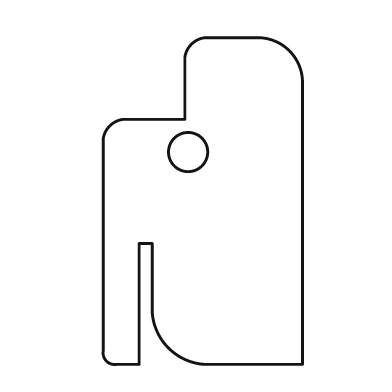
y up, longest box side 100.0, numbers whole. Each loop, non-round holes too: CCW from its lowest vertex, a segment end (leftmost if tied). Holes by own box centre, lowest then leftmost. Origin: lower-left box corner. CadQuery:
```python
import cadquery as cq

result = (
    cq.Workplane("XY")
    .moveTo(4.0, 0.0)
    .lineTo(11.0, 0.0)
    .lineTo(11.0, 37.0)
    .lineTo(15.0, 37.0)
    .lineTo(15.0, 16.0)
    .threePointArc((20.0, 5.0), (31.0, 0.0))
    .lineTo(61.0, 0.0)
    .lineTo(61.0, 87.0)
    .threePointArc((57.0, 96.0), (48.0, 100.0))
    .lineTo(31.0, 100.0)
    .threePointArc((27.0, 98.0), (25.0, 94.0))
    .lineTo(25.0, 75.0)
    .lineTo(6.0, 75.0)
    .threePointArc((2.0, 73.0), (0.0, 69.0))
    .lineTo(0.0, 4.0)
    .threePointArc((1.0, 1.0), (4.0, 0.0))
    .close()
    .moveTo(26.0, 65.0)
    .circle(6.0)
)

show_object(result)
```